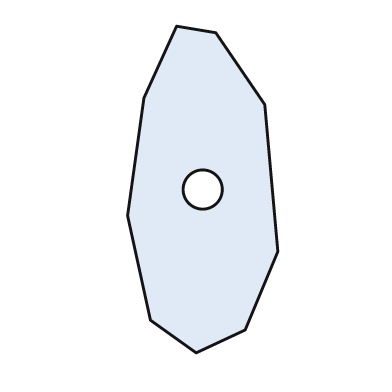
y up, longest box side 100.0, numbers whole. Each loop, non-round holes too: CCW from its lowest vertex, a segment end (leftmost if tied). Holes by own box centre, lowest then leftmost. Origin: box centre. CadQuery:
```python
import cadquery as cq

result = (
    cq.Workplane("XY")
    .moveTo(-2.0, -50.0)
    .lineTo(13.0, -43.0)
    .lineTo(23.0, -19.0)
    .lineTo(19.0, 26.0)
    .lineTo(4.0, 48.0)
    .lineTo(-8.0, 50.0)
    .lineTo(-18.0, 28.0)
    .lineTo(-23.0, -8.0)
    .lineTo(-16.0, -40.0)
    .close()
    .moveTo(0.0, 0.0)
    .circle(6.0)
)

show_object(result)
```